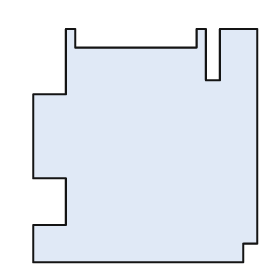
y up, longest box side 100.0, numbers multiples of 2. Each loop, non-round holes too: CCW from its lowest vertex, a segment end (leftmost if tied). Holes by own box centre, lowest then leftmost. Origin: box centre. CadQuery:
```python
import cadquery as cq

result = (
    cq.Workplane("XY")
    .moveTo(-48.0, -50.0)
    .lineTo(42.0, -50.0)
    .lineTo(42.0, -42.0)
    .lineTo(48.0, -42.0)
    .lineTo(48.0, 50.0)
    .lineTo(32.0, 50.0)
    .lineTo(32.0, 28.0)
    .lineTo(26.0, 28.0)
    .lineTo(26.0, 50.0)
    .lineTo(22.0, 50.0)
    .lineTo(22.0, 42.0)
    .lineTo(-30.0, 42.0)
    .lineTo(-30.0, 50.0)
    .lineTo(-34.0, 50.0)
    .lineTo(-34.0, 22.0)
    .lineTo(-48.0, 22.0)
    .lineTo(-48.0, -14.0)
    .lineTo(-34.0, -14.0)
    .lineTo(-34.0, -34.0)
    .lineTo(-48.0, -34.0)
    .close()
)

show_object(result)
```